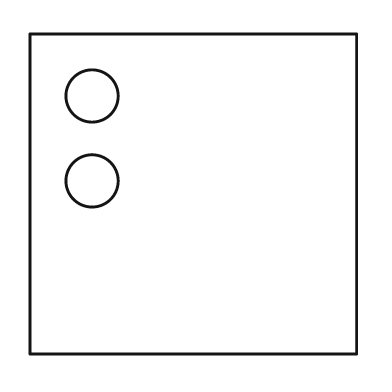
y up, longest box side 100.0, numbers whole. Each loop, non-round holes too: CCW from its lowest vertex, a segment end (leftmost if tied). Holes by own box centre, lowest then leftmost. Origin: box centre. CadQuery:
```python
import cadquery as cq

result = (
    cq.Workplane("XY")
    .moveTo(-50.0, -49.0)
    .lineTo(50.0, -49.0)
    .lineTo(50.0, 49.0)
    .lineTo(-50.0, 49.0)
    .close()
    .moveTo(-31.0, 4.0)
    .circle(8.0)
    .moveTo(-31.0, 30.0)
    .circle(8.0)
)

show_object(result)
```